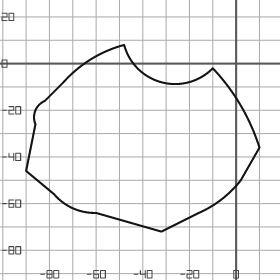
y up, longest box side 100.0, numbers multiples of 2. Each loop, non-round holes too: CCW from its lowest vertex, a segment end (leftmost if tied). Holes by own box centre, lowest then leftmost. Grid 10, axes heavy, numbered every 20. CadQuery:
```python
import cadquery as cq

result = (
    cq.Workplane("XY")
    .moveTo(-32.0, -72.0)
    .lineTo(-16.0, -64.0)
    .threePointArc((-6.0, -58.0), (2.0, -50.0))
    .lineTo(10.0, -36.0)
    .threePointArc((2.0, -18.0), (-10.0, -2.0))
    .threePointArc((-32.0, -8.0), (-48.0, 8.0))
    .threePointArc((-62.0, 2.0), (-74.0, -8.0))
    .lineTo(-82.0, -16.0)
    .threePointArc((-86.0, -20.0), (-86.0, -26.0))
    .lineTo(-90.0, -46.0)
    .lineTo(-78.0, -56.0)
    .threePointArc((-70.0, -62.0), (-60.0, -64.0))
    .close()
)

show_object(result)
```